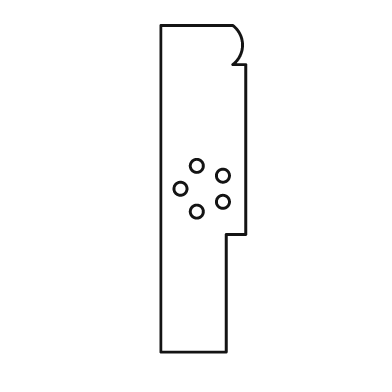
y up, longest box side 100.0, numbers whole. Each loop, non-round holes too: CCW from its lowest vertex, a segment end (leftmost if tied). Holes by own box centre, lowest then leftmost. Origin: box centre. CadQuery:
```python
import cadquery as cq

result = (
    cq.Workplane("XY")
    .moveTo(-13.0, -50.0)
    .lineTo(7.0, -50.0)
    .lineTo(7.0, -14.0)
    .lineTo(13.0, -14.0)
    .lineTo(13.0, 38.0)
    .lineTo(9.0, 38.0)
    .threePointArc((12.0, 44.0), (9.0, 50.0))
    .lineTo(-13.0, 50.0)
    .close()
    .moveTo(-2.0, -7.0)
    .circle(2.0)
    .moveTo(6.0, -4.0)
    .circle(2.0)
    .moveTo(-7.0, 0.0)
    .circle(2.0)
    .moveTo(6.0, 4.0)
    .circle(2.0)
    .moveTo(-2.0, 7.0)
    .circle(2.0)
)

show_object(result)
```